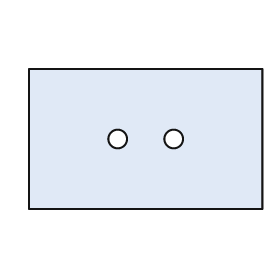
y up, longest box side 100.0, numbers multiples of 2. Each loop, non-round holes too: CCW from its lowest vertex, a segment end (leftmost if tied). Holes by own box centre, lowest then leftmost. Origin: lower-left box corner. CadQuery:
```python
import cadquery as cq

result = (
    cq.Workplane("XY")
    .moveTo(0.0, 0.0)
    .lineTo(100.0, 0.0)
    .lineTo(100.0, 60.0)
    .lineTo(0.0, 60.0)
    .close()
    .moveTo(38.0, 30.0)
    .circle(4.0)
    .moveTo(62.0, 30.0)
    .circle(4.0)
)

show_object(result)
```